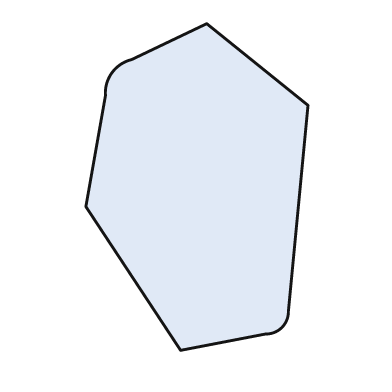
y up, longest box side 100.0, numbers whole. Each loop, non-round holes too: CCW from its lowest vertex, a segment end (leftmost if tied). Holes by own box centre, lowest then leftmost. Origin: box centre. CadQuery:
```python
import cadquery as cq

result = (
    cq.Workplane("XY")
    .moveTo(-5.0, -50.0)
    .lineTo(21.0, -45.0)
    .threePointArc((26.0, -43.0), (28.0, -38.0))
    .lineTo(34.0, 25.0)
    .lineTo(3.0, 50.0)
    .lineTo(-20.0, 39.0)
    .threePointArc((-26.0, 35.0), (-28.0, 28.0))
    .lineTo(-34.0, -6.0)
    .close()
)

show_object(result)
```